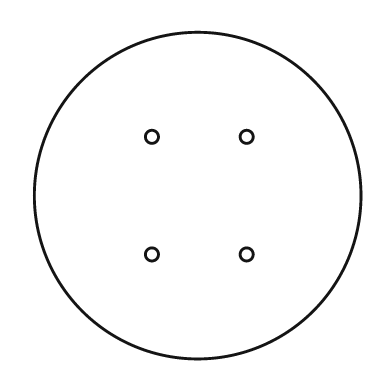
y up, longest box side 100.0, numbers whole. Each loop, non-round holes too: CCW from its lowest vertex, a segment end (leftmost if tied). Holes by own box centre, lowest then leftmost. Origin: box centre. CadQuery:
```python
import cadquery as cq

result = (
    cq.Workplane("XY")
    .moveTo(0.0, 0.0)
    .circle(50.0)
    .moveTo(-14.0, -18.0)
    .circle(2.0)
    .moveTo(15.0, -18.0)
    .circle(2.0)
    .moveTo(-14.0, 18.0)
    .circle(2.0)
    .moveTo(15.0, 18.0)
    .circle(2.0)
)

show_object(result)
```